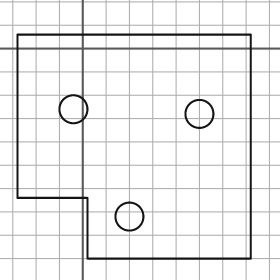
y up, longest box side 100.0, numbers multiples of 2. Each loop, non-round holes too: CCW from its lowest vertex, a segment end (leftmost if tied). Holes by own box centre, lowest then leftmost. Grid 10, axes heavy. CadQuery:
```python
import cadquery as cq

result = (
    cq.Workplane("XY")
    .moveTo(2.0, -90.0)
    .lineTo(72.0, -90.0)
    .lineTo(72.0, 6.0)
    .lineTo(-28.0, 6.0)
    .lineTo(-28.0, -64.0)
    .lineTo(2.0, -64.0)
    .close()
    .moveTo(20.0, -72.0)
    .circle(6.0)
    .moveTo(50.0, -28.0)
    .circle(6.0)
    .moveTo(-4.0, -26.0)
    .circle(6.0)
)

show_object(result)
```